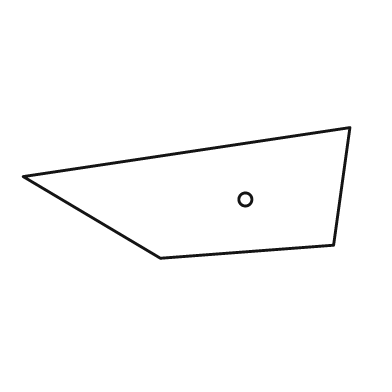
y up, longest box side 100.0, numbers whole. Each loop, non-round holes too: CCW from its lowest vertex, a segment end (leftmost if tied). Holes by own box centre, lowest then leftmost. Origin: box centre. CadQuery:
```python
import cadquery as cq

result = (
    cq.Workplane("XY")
    .moveTo(-8.0, -20.0)
    .lineTo(45.0, -16.0)
    .lineTo(50.0, 20.0)
    .lineTo(-50.0, 5.0)
    .close()
    .moveTo(18.0, -2.0)
    .circle(2.0)
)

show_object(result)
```